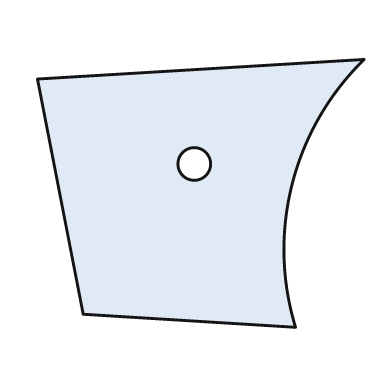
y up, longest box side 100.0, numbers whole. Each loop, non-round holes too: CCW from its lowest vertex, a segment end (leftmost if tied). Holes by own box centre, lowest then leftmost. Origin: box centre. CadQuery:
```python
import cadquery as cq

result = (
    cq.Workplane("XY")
    .moveTo(29.0, -41.0)
    .threePointArc((28.0, 3.0), (50.0, 41.0))
    .lineTo(-50.0, 35.0)
    .lineTo(-36.0, -37.0)
    .close()
    .moveTo(-2.0, 9.0)
    .circle(5.0)
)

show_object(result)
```